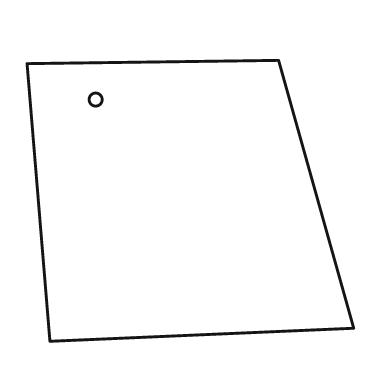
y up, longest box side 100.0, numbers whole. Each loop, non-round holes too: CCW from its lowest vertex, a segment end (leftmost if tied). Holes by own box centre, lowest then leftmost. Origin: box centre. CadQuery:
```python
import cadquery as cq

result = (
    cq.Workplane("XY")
    .moveTo(-43.0, -43.0)
    .lineTo(50.0, -39.0)
    .lineTo(27.0, 43.0)
    .lineTo(-50.0, 42.0)
    .close()
    .moveTo(-29.0, 31.0)
    .circle(2.0)
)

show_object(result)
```